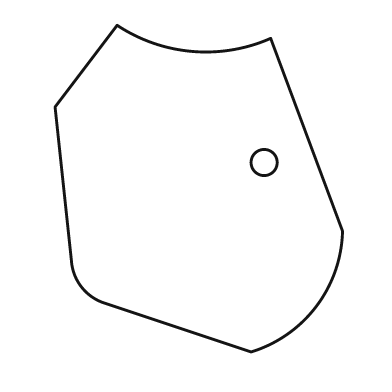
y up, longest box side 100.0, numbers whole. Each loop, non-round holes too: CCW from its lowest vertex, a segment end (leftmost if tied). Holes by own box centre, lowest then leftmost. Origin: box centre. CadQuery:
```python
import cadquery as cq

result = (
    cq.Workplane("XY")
    .moveTo(16.0, -50.0)
    .threePointArc((36.0, -36.0), (44.0, -13.0))
    .lineTo(22.0, 46.0)
    .threePointArc((-2.0, 42.0), (-25.0, 50.0))
    .lineTo(-44.0, 25.0)
    .lineTo(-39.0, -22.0)
    .threePointArc((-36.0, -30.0), (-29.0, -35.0))
    .close()
    .moveTo(20.0, 8.0)
    .circle(4.0)
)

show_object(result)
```